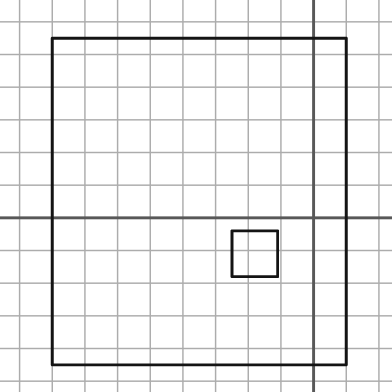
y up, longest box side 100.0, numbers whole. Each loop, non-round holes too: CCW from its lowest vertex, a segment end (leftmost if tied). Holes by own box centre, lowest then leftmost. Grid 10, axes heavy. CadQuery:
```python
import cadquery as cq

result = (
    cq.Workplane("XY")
    .moveTo(-80.0, -45.0)
    .lineTo(10.0, -45.0)
    .lineTo(10.0, 55.0)
    .lineTo(-80.0, 55.0)
    .close()
    .moveTo(-25.0, -18.0)
    .lineTo(-11.0, -18.0)
    .lineTo(-11.0, -4.0)
    .lineTo(-25.0, -4.0)
    .close()
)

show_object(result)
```